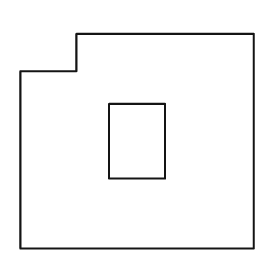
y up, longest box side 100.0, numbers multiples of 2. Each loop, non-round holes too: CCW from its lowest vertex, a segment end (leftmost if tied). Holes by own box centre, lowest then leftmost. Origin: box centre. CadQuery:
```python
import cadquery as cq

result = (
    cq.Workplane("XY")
    .moveTo(-50.0, -46.0)
    .lineTo(50.0, -46.0)
    .lineTo(50.0, 46.0)
    .lineTo(-26.0, 46.0)
    .lineTo(-26.0, 30.0)
    .lineTo(-50.0, 30.0)
    .close()
    .moveTo(-12.0, -16.0)
    .lineTo(12.0, -16.0)
    .lineTo(12.0, 16.0)
    .lineTo(-12.0, 16.0)
    .close()
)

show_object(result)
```